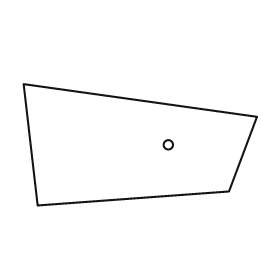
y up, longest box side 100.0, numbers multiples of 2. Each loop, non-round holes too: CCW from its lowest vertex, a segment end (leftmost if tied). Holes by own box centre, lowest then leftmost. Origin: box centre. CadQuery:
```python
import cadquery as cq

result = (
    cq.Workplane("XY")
    .moveTo(-44.0, -26.0)
    .lineTo(38.0, -20.0)
    .lineTo(50.0, 12.0)
    .lineTo(-50.0, 26.0)
    .close()
    .moveTo(12.0, 0.0)
    .circle(2.0)
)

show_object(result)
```